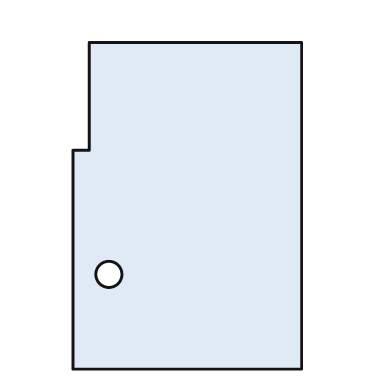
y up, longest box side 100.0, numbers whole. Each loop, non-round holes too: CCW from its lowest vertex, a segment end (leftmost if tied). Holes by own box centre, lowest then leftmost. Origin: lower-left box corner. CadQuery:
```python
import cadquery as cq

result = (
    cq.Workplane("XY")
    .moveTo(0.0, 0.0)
    .lineTo(70.0, 0.0)
    .lineTo(70.0, 100.0)
    .lineTo(5.0, 100.0)
    .lineTo(5.0, 67.0)
    .lineTo(0.0, 67.0)
    .close()
    .moveTo(11.0, 29.0)
    .circle(4.0)
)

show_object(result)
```